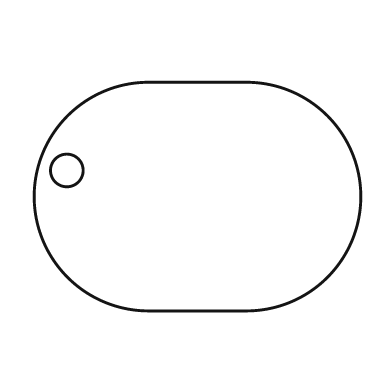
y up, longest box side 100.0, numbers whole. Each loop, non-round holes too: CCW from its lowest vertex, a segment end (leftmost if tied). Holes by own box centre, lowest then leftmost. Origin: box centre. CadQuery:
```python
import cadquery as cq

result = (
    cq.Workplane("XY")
    .moveTo(-15.0, -35.0)
    .lineTo(15.0, -35.0)
    .threePointArc((50.0, 0.0), (15.0, 35.0))
    .lineTo(-15.0, 35.0)
    .threePointArc((-50.0, 0.0), (-15.0, -35.0))
    .close()
    .moveTo(-40.0, 8.0)
    .circle(5.0)
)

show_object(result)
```